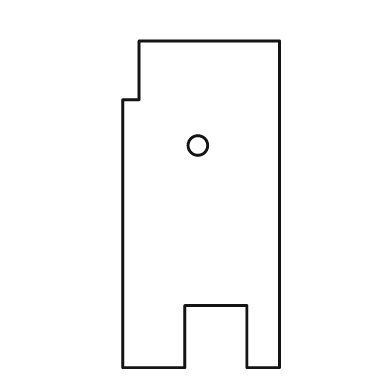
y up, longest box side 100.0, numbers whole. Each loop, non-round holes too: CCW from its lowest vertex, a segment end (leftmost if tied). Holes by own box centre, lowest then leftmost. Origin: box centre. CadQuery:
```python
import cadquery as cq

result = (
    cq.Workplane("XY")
    .moveTo(-24.0, -50.0)
    .lineTo(-5.0, -50.0)
    .lineTo(-5.0, -31.0)
    .lineTo(14.0, -31.0)
    .lineTo(14.0, -50.0)
    .lineTo(24.0, -50.0)
    .lineTo(24.0, 50.0)
    .lineTo(-19.0, 50.0)
    .lineTo(-19.0, 32.0)
    .lineTo(-24.0, 32.0)
    .close()
    .moveTo(-1.0, 18.0)
    .circle(3.0)
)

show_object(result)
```